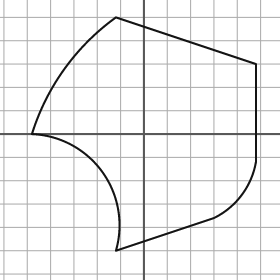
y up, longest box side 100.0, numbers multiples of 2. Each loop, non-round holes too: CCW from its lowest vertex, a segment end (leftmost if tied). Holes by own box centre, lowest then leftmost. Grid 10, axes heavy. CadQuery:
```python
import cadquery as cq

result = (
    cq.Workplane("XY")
    .moveTo(-12.0, -50.0)
    .lineTo(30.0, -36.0)
    .threePointArc((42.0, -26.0), (48.0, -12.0))
    .lineTo(48.0, 30.0)
    .lineTo(-12.0, 50.0)
    .threePointArc((-34.0, 28.0), (-48.0, 0.0))
    .threePointArc((-18.0, -16.0), (-12.0, -50.0))
    .close()
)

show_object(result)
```